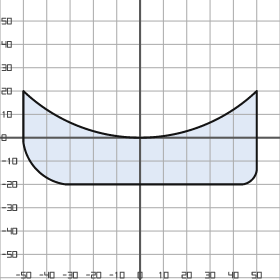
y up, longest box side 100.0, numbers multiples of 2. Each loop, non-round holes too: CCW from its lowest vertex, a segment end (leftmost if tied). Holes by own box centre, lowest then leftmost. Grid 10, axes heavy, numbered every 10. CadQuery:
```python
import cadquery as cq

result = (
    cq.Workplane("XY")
    .moveTo(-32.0, -20.0)
    .lineTo(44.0, -20.0)
    .threePointArc((48.0, -18.0), (50.0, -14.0))
    .lineTo(50.0, 20.0)
    .threePointArc((0.0, 0.0), (-50.0, 20.0))
    .lineTo(-50.0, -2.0)
    .threePointArc((-44.0, -14.0), (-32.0, -20.0))
    .close()
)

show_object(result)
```